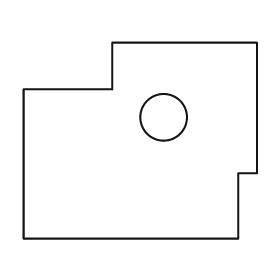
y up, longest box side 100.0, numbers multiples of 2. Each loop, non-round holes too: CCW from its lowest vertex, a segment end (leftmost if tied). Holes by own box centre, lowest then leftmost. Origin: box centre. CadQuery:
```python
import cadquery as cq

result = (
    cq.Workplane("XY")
    .moveTo(-50.0, -42.0)
    .lineTo(42.0, -42.0)
    .lineTo(42.0, -14.0)
    .lineTo(50.0, -14.0)
    .lineTo(50.0, 42.0)
    .lineTo(-12.0, 42.0)
    .lineTo(-12.0, 22.0)
    .lineTo(-50.0, 22.0)
    .close()
    .moveTo(10.0, 10.0)
    .circle(10.0)
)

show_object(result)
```